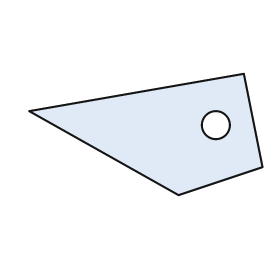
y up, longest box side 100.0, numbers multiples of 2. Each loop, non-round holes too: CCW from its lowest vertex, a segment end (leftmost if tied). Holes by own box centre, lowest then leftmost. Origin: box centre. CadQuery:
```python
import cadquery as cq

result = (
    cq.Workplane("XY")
    .moveTo(14.0, -26.0)
    .lineTo(50.0, -14.0)
    .lineTo(42.0, 26.0)
    .lineTo(-50.0, 10.0)
    .close()
    .moveTo(30.0, 4.0)
    .circle(6.0)
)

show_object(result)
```